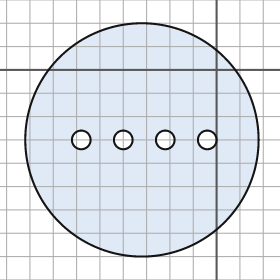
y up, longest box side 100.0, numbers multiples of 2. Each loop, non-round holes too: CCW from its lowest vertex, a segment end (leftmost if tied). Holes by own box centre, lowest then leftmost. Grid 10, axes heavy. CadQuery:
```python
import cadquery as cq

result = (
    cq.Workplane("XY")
    .moveTo(-32.0, -30.0)
    .circle(50.0)
    .moveTo(-58.0, -30.0)
    .circle(4.0)
    .moveTo(-40.0, -30.0)
    .circle(4.0)
    .moveTo(-22.0, -30.0)
    .circle(4.0)
    .moveTo(-4.0, -30.0)
    .circle(4.0)
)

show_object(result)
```